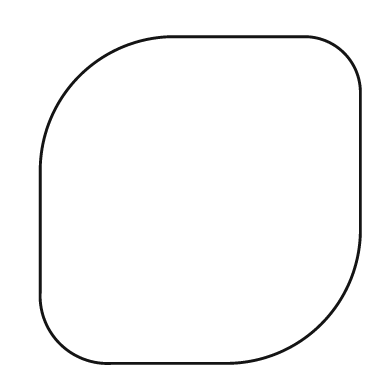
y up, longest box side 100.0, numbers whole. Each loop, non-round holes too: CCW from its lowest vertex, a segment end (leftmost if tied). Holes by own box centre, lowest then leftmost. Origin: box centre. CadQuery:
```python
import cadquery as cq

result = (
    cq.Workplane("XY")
    .moveTo(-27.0, -50.0)
    .lineTo(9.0, -50.0)
    .threePointArc((37.0, -38.0), (49.0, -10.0))
    .lineTo(49.0, 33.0)
    .threePointArc((44.0, 45.0), (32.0, 50.0))
    .lineTo(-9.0, 50.0)
    .threePointArc((-37.0, 38.0), (-49.0, 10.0))
    .lineTo(-49.0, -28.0)
    .threePointArc((-43.0, -44.0), (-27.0, -50.0))
    .close()
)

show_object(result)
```